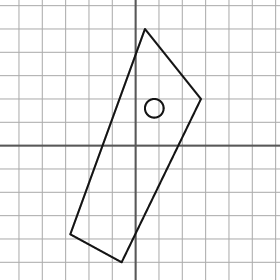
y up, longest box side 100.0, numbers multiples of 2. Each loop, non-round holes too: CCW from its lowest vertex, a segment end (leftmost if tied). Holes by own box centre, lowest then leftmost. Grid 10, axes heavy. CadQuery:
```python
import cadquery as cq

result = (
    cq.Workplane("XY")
    .moveTo(-6.0, -50.0)
    .lineTo(28.0, 20.0)
    .lineTo(4.0, 50.0)
    .lineTo(-28.0, -38.0)
    .close()
    .moveTo(8.0, 16.0)
    .circle(4.0)
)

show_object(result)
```